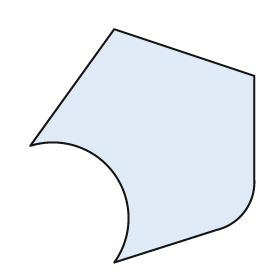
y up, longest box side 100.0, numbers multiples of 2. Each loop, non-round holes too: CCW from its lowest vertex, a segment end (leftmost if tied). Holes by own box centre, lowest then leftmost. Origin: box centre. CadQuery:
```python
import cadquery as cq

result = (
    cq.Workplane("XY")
    .moveTo(-12.0, -50.0)
    .lineTo(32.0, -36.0)
    .threePointArc((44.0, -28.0), (48.0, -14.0))
    .lineTo(48.0, 30.0)
    .lineTo(-12.0, 50.0)
    .lineTo(-48.0, 0.0)
    .threePointArc((-12.0, -12.0), (-12.0, -50.0))
    .close()
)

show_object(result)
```